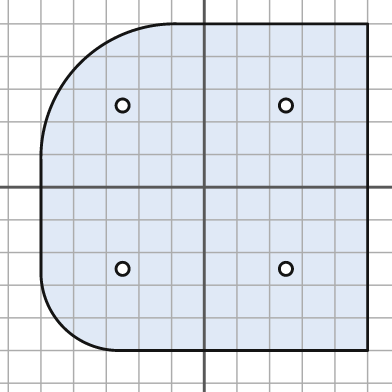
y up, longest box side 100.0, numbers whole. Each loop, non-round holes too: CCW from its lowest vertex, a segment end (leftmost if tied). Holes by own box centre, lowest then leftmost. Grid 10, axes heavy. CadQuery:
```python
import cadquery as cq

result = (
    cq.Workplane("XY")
    .moveTo(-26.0, -50.0)
    .lineTo(50.0, -50.0)
    .lineTo(50.0, 50.0)
    .lineTo(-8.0, 50.0)
    .threePointArc((-38.0, 38.0), (-50.0, 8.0))
    .lineTo(-50.0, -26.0)
    .threePointArc((-43.0, -43.0), (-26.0, -50.0))
    .close()
    .moveTo(-25.0, -25.0)
    .circle(2.0)
    .moveTo(25.0, -25.0)
    .circle(2.0)
    .moveTo(-25.0, 25.0)
    .circle(2.0)
    .moveTo(25.0, 25.0)
    .circle(2.0)
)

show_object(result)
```